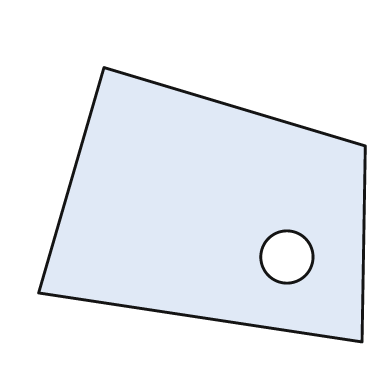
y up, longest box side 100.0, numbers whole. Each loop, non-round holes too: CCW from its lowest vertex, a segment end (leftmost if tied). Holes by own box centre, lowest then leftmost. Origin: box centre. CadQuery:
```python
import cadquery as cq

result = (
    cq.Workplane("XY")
    .moveTo(49.0, -42.0)
    .lineTo(50.0, 18.0)
    .lineTo(-30.0, 42.0)
    .lineTo(-50.0, -27.0)
    .close()
    .moveTo(26.0, -16.0)
    .circle(8.0)
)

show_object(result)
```